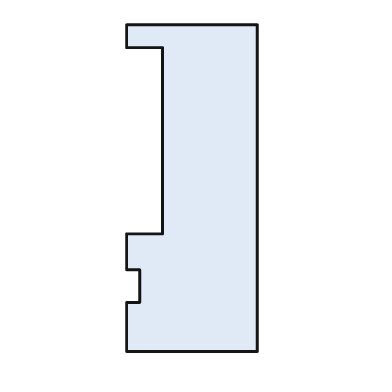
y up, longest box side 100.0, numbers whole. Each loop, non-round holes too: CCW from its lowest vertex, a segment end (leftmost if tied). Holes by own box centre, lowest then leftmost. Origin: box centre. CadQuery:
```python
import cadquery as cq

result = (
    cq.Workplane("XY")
    .moveTo(-20.0, -50.0)
    .lineTo(20.0, -50.0)
    .lineTo(20.0, 50.0)
    .lineTo(-20.0, 50.0)
    .lineTo(-20.0, 43.0)
    .lineTo(-9.0, 43.0)
    .lineTo(-9.0, -14.0)
    .lineTo(-20.0, -14.0)
    .lineTo(-20.0, -25.0)
    .lineTo(-16.0, -25.0)
    .lineTo(-16.0, -35.0)
    .lineTo(-20.0, -35.0)
    .close()
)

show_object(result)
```